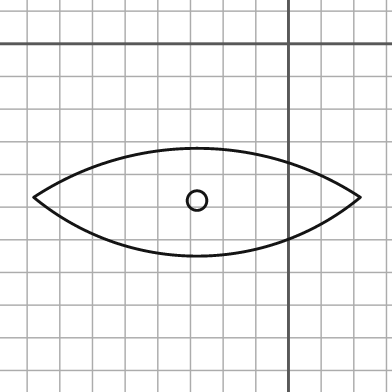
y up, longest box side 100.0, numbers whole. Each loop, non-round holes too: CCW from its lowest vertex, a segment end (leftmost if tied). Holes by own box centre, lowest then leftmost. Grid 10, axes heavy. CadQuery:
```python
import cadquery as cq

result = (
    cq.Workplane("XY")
    .moveTo(-78.0, -47.0)
    .threePointArc((-28.0, -65.0), (22.0, -47.0))
    .threePointArc((-28.0, -32.0), (-78.0, -47.0))
    .close()
    .moveTo(-28.0, -48.0)
    .circle(3.0)
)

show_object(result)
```